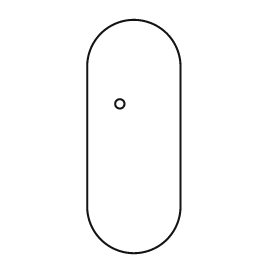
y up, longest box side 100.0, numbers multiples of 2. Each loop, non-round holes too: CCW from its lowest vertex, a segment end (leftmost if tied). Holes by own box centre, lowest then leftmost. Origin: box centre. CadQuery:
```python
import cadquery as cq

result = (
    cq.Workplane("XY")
    .moveTo(-20.0, -30.0)
    .threePointArc((0.0, -50.0), (20.0, -30.0))
    .lineTo(20.0, 30.0)
    .threePointArc((0.0, 50.0), (-20.0, 30.0))
    .close()
    .moveTo(-6.0, 14.0)
    .circle(2.0)
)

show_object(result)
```